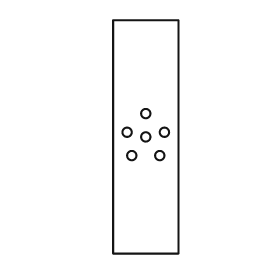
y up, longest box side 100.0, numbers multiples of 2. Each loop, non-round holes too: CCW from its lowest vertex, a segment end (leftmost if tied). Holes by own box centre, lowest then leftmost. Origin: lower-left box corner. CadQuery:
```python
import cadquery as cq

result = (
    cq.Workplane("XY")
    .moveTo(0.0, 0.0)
    .lineTo(28.0, 0.0)
    .lineTo(28.0, 100.0)
    .lineTo(0.0, 100.0)
    .close()
    .moveTo(8.0, 42.0)
    .circle(2.0)
    .moveTo(20.0, 42.0)
    .circle(2.0)
    .moveTo(14.0, 50.0)
    .circle(2.0)
    .moveTo(6.0, 52.0)
    .circle(2.0)
    .moveTo(22.0, 52.0)
    .circle(2.0)
    .moveTo(14.0, 60.0)
    .circle(2.0)
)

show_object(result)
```